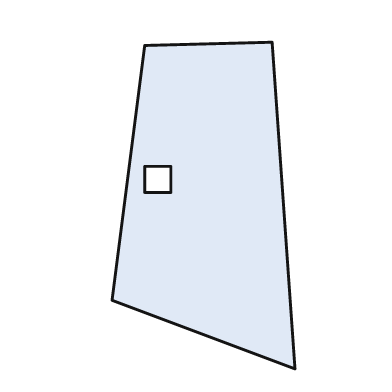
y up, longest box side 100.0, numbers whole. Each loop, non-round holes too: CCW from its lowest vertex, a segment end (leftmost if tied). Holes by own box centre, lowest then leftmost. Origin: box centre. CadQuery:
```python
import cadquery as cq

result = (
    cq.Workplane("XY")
    .moveTo(28.0, -50.0)
    .lineTo(21.0, 50.0)
    .lineTo(-18.0, 49.0)
    .lineTo(-28.0, -29.0)
    .close()
    .moveTo(-18.0, 4.0)
    .lineTo(-10.0, 4.0)
    .lineTo(-10.0, 12.0)
    .lineTo(-18.0, 12.0)
    .close()
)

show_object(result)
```